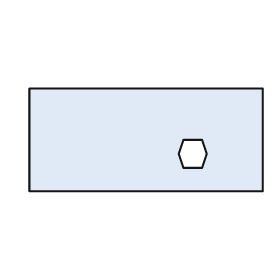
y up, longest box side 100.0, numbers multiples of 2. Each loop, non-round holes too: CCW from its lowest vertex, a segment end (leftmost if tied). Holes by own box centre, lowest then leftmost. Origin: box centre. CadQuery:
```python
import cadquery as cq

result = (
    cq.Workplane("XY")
    .moveTo(-50.0, -22.0)
    .lineTo(50.0, -22.0)
    .lineTo(50.0, 22.0)
    .lineTo(-50.0, 22.0)
    .close()
    .moveTo(16.0, -12.0)
    .lineTo(24.0, -12.0)
    .lineTo(26.0, -6.0)
    .lineTo(24.0, 0.0)
    .lineTo(16.0, 0.0)
    .lineTo(14.0, -6.0)
    .close()
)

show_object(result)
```